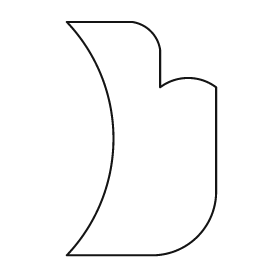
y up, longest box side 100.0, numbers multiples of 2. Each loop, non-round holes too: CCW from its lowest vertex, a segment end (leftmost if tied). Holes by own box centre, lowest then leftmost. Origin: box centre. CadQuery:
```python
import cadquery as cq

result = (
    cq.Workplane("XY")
    .moveTo(-32.0, -50.0)
    .lineTo(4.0, -50.0)
    .threePointArc((24.0, -42.0), (32.0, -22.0))
    .lineTo(32.0, 22.0)
    .threePointArc((20.0, 26.0), (8.0, 22.0))
    .lineTo(8.0, 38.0)
    .threePointArc((4.0, 46.0), (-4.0, 50.0))
    .lineTo(-32.0, 50.0)
    .threePointArc((-12.0, 0.0), (-32.0, -50.0))
    .close()
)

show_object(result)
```